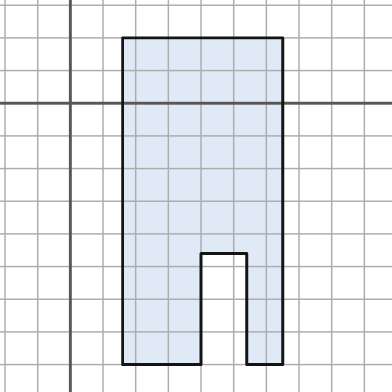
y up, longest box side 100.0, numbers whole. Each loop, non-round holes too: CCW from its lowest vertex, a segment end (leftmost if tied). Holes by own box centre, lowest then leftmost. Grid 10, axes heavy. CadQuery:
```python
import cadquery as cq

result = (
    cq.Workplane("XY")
    .moveTo(16.0, -80.0)
    .lineTo(40.0, -80.0)
    .lineTo(40.0, -46.0)
    .lineTo(54.0, -46.0)
    .lineTo(54.0, -80.0)
    .lineTo(65.0, -80.0)
    .lineTo(65.0, 20.0)
    .lineTo(16.0, 20.0)
    .close()
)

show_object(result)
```